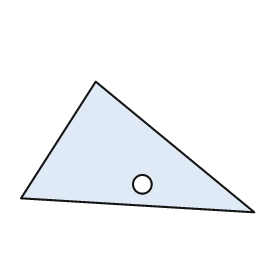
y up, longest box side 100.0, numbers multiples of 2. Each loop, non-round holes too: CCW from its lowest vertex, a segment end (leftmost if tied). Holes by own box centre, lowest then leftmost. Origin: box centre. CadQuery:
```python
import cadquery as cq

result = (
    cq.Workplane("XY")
    .moveTo(50.0, -28.0)
    .lineTo(-18.0, 28.0)
    .lineTo(-50.0, -22.0)
    .close()
    .moveTo(2.0, -16.0)
    .circle(4.0)
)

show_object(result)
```